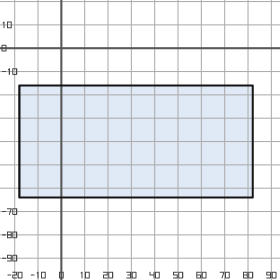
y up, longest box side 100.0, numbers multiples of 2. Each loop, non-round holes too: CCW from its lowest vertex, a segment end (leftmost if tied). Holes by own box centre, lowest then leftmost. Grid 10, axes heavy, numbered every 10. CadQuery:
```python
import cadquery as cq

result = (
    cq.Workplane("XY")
    .moveTo(-18.0, -64.0)
    .lineTo(82.0, -64.0)
    .lineTo(82.0, -16.0)
    .lineTo(-18.0, -16.0)
    .close()
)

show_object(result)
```